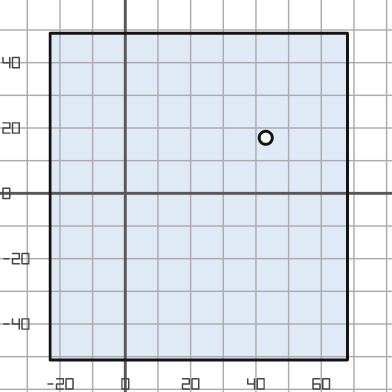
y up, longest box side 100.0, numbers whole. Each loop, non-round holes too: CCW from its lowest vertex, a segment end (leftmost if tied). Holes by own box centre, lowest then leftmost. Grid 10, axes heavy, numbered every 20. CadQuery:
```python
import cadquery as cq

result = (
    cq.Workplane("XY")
    .moveTo(-23.0, -51.0)
    .lineTo(68.0, -51.0)
    .lineTo(68.0, 49.0)
    .lineTo(-23.0, 49.0)
    .close()
    .moveTo(43.0, 17.0)
    .circle(2.0)
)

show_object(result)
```